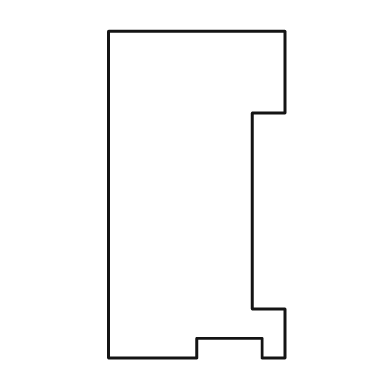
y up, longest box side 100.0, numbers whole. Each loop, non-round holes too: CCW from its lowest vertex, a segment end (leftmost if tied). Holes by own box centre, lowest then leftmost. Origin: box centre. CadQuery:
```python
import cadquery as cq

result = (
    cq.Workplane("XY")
    .moveTo(-27.0, -50.0)
    .lineTo(0.0, -50.0)
    .lineTo(0.0, -44.0)
    .lineTo(20.0, -44.0)
    .lineTo(20.0, -50.0)
    .lineTo(27.0, -50.0)
    .lineTo(27.0, -35.0)
    .lineTo(17.0, -35.0)
    .lineTo(17.0, 25.0)
    .lineTo(27.0, 25.0)
    .lineTo(27.0, 50.0)
    .lineTo(-27.0, 50.0)
    .close()
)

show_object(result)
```